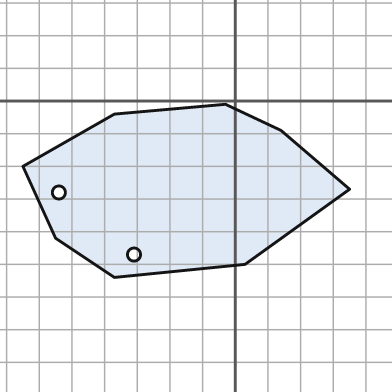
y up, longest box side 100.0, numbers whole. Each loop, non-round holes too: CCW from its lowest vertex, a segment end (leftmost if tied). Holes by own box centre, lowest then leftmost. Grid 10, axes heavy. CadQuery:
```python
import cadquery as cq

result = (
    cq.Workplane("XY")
    .moveTo(-37.0, -54.0)
    .lineTo(3.0, -50.0)
    .lineTo(35.0, -27.0)
    .lineTo(14.0, -9.0)
    .lineTo(-3.0, -1.0)
    .lineTo(-37.0, -4.0)
    .lineTo(-65.0, -20.0)
    .lineTo(-55.0, -42.0)
    .close()
    .moveTo(-31.0, -47.0)
    .circle(2.0)
    .moveTo(-54.0, -28.0)
    .circle(2.0)
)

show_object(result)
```